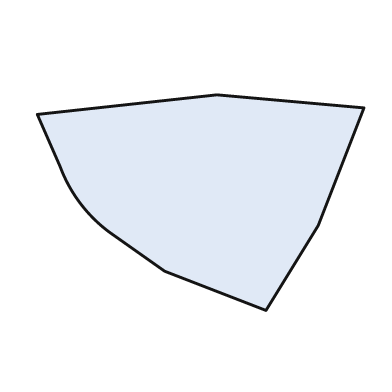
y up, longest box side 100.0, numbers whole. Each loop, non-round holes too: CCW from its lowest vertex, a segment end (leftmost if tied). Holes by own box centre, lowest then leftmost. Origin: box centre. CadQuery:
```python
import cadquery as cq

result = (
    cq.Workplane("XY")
    .moveTo(20.0, -33.0)
    .lineTo(36.0, -7.0)
    .lineTo(50.0, 29.0)
    .lineTo(5.0, 33.0)
    .lineTo(-50.0, 27.0)
    .lineTo(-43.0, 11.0)
    .threePointArc((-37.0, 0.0), (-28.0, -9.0))
    .lineTo(-11.0, -21.0)
    .close()
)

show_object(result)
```